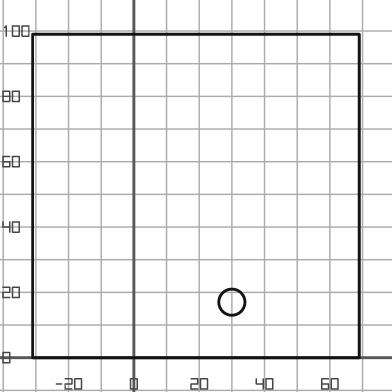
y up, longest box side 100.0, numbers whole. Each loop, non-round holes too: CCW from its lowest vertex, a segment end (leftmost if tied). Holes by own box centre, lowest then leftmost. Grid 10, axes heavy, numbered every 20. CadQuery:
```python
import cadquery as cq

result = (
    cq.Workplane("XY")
    .moveTo(-31.0, 0.0)
    .lineTo(69.0, 0.0)
    .lineTo(69.0, 99.0)
    .lineTo(-31.0, 99.0)
    .close()
    .moveTo(30.0, 17.0)
    .circle(4.0)
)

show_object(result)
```